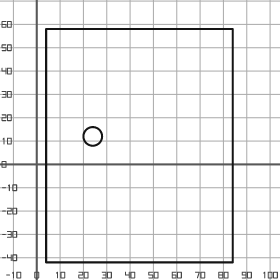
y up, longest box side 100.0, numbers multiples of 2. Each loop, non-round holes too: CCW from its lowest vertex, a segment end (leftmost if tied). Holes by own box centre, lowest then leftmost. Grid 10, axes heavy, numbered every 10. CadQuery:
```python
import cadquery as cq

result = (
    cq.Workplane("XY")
    .moveTo(4.0, -42.0)
    .lineTo(84.0, -42.0)
    .lineTo(84.0, 58.0)
    .lineTo(4.0, 58.0)
    .close()
    .moveTo(24.0, 12.0)
    .circle(4.0)
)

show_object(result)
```